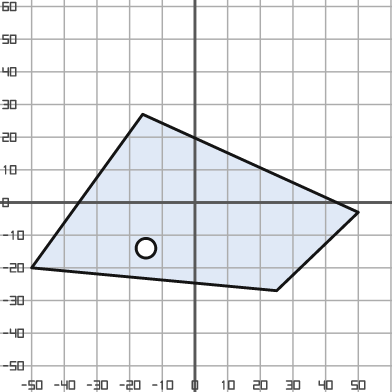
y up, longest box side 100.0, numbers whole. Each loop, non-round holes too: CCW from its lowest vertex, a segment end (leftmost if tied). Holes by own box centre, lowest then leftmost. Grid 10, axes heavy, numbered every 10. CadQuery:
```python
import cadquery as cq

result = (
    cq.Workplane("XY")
    .moveTo(25.0, -27.0)
    .lineTo(50.0, -3.0)
    .lineTo(-16.0, 27.0)
    .lineTo(-50.0, -20.0)
    .close()
    .moveTo(-15.0, -14.0)
    .circle(3.0)
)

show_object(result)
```